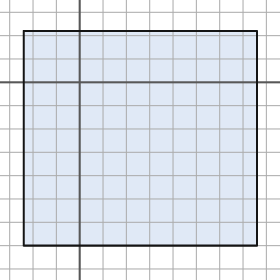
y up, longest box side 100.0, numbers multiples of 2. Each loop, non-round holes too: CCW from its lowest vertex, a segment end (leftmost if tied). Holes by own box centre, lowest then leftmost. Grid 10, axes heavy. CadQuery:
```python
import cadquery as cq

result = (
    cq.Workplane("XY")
    .moveTo(-24.0, -70.0)
    .lineTo(76.0, -70.0)
    .lineTo(76.0, 22.0)
    .lineTo(-24.0, 22.0)
    .close()
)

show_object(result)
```